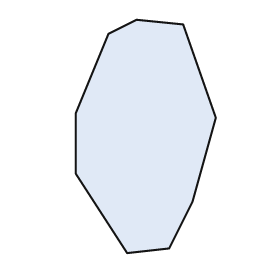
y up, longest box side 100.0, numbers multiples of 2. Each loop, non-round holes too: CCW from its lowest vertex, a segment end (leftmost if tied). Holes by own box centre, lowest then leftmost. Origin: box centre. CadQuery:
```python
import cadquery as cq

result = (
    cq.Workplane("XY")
    .moveTo(-8.0, -50.0)
    .lineTo(10.0, -48.0)
    .lineTo(20.0, -28.0)
    .lineTo(30.0, 8.0)
    .lineTo(16.0, 48.0)
    .lineTo(-4.0, 50.0)
    .lineTo(-16.0, 44.0)
    .lineTo(-30.0, 10.0)
    .lineTo(-30.0, -16.0)
    .close()
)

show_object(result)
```